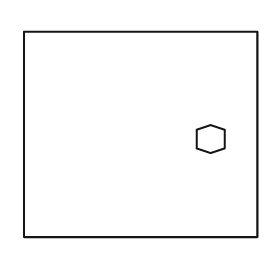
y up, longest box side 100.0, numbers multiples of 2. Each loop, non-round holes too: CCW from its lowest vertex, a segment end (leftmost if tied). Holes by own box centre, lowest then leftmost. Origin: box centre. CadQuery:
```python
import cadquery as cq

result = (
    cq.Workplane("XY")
    .moveTo(-50.0, -44.0)
    .lineTo(50.0, -44.0)
    .lineTo(50.0, 44.0)
    .lineTo(-50.0, 44.0)
    .close()
    .moveTo(30.0, -8.0)
    .lineTo(36.0, -6.0)
    .lineTo(36.0, 2.0)
    .lineTo(30.0, 4.0)
    .lineTo(24.0, 2.0)
    .lineTo(24.0, -6.0)
    .close()
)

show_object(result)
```